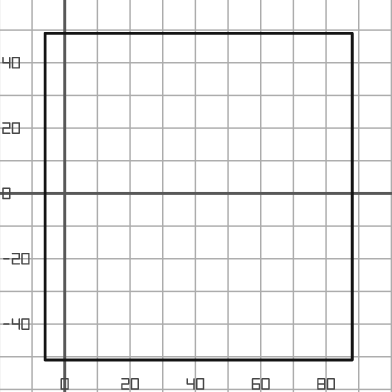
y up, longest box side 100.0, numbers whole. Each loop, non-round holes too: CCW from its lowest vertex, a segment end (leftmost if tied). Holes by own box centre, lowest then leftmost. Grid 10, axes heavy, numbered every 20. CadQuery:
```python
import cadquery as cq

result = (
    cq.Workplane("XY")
    .moveTo(-6.0, -51.0)
    .lineTo(88.0, -51.0)
    .lineTo(88.0, 49.0)
    .lineTo(-6.0, 49.0)
    .close()
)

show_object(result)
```